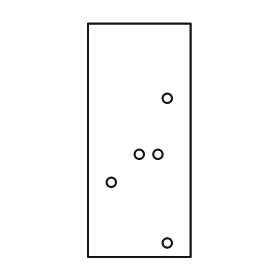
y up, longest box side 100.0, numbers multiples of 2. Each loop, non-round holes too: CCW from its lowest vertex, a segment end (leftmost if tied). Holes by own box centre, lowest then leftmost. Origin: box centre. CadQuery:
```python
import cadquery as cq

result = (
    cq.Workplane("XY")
    .moveTo(-22.0, -50.0)
    .lineTo(22.0, -50.0)
    .lineTo(22.0, 50.0)
    .lineTo(-22.0, 50.0)
    .close()
    .moveTo(12.0, -44.0)
    .circle(2.0)
    .moveTo(-12.0, -18.0)
    .circle(2.0)
    .moveTo(0.0, -6.0)
    .circle(2.0)
    .moveTo(8.0, -6.0)
    .circle(2.0)
    .moveTo(12.0, 18.0)
    .circle(2.0)
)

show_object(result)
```